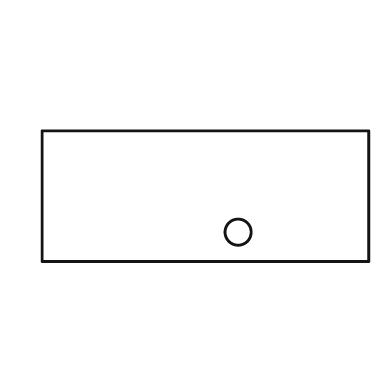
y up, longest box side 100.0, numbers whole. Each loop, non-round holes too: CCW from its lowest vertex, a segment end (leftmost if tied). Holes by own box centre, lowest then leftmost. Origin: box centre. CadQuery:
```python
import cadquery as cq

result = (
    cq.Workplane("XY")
    .moveTo(-50.0, -20.0)
    .lineTo(50.0, -20.0)
    .lineTo(50.0, 20.0)
    .lineTo(-50.0, 20.0)
    .close()
    .moveTo(10.0, -11.0)
    .circle(4.0)
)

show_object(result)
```